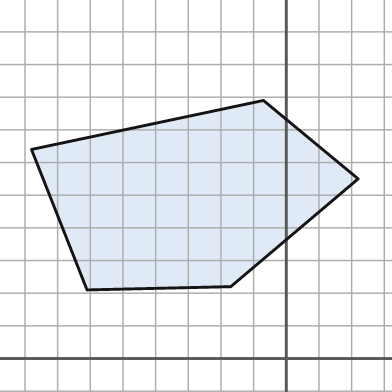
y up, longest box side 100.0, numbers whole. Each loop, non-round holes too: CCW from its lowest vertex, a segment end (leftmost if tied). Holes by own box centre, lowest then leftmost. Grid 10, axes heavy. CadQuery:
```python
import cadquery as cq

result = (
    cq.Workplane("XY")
    .moveTo(-61.0, 21.0)
    .lineTo(-17.0, 22.0)
    .lineTo(22.0, 55.0)
    .lineTo(-7.0, 79.0)
    .lineTo(-78.0, 64.0)
    .close()
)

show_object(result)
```